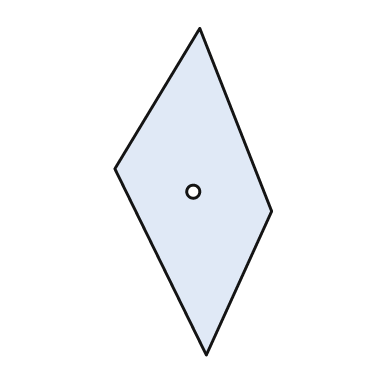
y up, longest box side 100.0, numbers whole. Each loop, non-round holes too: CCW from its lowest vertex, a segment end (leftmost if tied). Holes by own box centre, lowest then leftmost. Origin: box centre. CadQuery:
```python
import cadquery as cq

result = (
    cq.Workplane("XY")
    .moveTo(4.0, -50.0)
    .lineTo(24.0, -6.0)
    .lineTo(2.0, 50.0)
    .lineTo(-24.0, 7.0)
    .close()
    .moveTo(0.0, 0.0)
    .circle(2.0)
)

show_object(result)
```